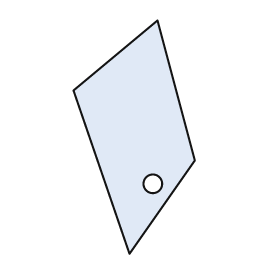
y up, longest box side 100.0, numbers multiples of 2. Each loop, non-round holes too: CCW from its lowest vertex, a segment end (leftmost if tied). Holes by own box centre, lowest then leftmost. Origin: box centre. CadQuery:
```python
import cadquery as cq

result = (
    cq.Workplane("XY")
    .moveTo(-2.0, -50.0)
    .lineTo(26.0, -10.0)
    .lineTo(10.0, 50.0)
    .lineTo(-26.0, 20.0)
    .close()
    .moveTo(8.0, -20.0)
    .circle(4.0)
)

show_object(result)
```